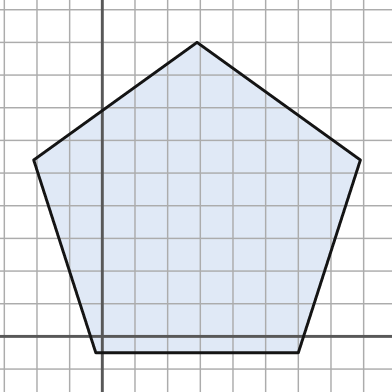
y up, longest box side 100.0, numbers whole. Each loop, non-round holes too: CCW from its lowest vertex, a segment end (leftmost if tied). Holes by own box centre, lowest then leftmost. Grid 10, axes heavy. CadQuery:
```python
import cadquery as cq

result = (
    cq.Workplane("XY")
    .moveTo(-2.0, -5.0)
    .lineTo(60.0, -5.0)
    .lineTo(79.0, 54.0)
    .lineTo(29.0, 90.0)
    .lineTo(-21.0, 54.0)
    .close()
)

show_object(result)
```